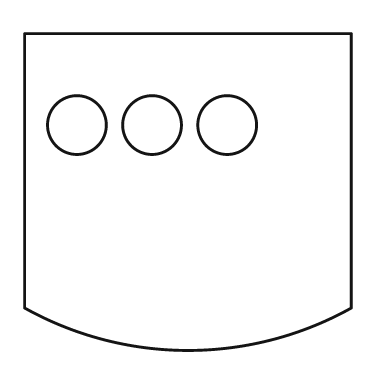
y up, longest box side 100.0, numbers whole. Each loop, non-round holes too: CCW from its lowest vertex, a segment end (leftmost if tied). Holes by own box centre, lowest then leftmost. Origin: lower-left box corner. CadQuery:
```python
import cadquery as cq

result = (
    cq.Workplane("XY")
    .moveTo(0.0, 13.0)
    .threePointArc((50.0, 0.0), (100.0, 13.0))
    .lineTo(100.0, 97.0)
    .lineTo(0.0, 97.0)
    .close()
    .moveTo(16.0, 69.0)
    .circle(9.0)
    .moveTo(39.0, 69.0)
    .circle(9.0)
    .moveTo(62.0, 69.0)
    .circle(9.0)
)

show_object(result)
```